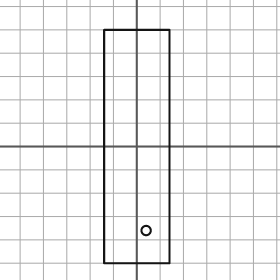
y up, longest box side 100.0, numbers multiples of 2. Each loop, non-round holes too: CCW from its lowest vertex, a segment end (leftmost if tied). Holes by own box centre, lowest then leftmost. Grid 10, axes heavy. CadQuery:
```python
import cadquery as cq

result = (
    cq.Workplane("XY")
    .moveTo(-14.0, -50.0)
    .lineTo(14.0, -50.0)
    .lineTo(14.0, 50.0)
    .lineTo(-14.0, 50.0)
    .close()
    .moveTo(4.0, -36.0)
    .circle(2.0)
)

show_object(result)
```